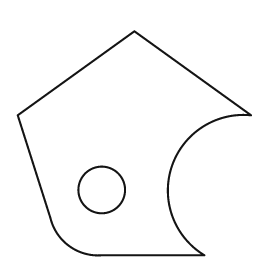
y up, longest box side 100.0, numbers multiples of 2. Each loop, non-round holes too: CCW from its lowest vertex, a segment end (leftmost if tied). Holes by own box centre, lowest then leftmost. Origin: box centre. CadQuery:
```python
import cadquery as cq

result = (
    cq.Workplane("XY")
    .moveTo(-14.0, -48.0)
    .lineTo(30.0, -48.0)
    .threePointArc((16.0, -10.0), (50.0, 12.0))
    .lineTo(0.0, 48.0)
    .lineTo(-50.0, 12.0)
    .lineTo(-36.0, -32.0)
    .threePointArc((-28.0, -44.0), (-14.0, -48.0))
    .close()
    .moveTo(-14.0, -20.0)
    .circle(10.0)
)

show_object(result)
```